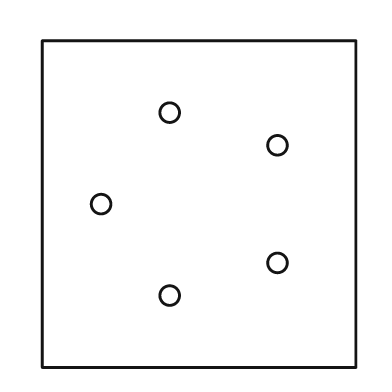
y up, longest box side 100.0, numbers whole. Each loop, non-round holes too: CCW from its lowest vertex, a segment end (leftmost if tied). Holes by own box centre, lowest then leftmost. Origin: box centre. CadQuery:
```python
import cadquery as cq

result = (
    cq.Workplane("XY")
    .moveTo(-48.0, -50.0)
    .lineTo(48.0, -50.0)
    .lineTo(48.0, 50.0)
    .lineTo(-48.0, 50.0)
    .close()
    .moveTo(-9.0, -28.0)
    .circle(3.0)
    .moveTo(24.0, -18.0)
    .circle(3.0)
    .moveTo(-30.0, 0.0)
    .circle(3.0)
    .moveTo(24.0, 18.0)
    .circle(3.0)
    .moveTo(-9.0, 28.0)
    .circle(3.0)
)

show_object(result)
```